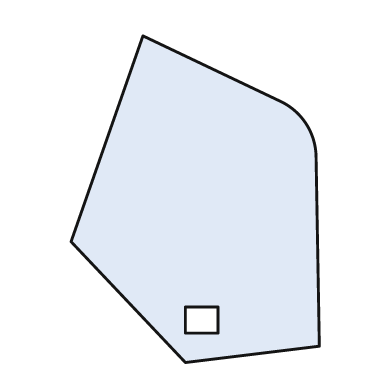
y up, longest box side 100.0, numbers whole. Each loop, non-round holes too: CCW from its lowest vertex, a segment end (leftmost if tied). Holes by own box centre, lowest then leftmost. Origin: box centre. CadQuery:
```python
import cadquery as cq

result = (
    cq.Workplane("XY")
    .moveTo(-3.0, -50.0)
    .lineTo(38.0, -45.0)
    .lineTo(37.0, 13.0)
    .threePointArc((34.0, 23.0), (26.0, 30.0))
    .lineTo(-16.0, 50.0)
    .lineTo(-38.0, -13.0)
    .close()
    .moveTo(-3.0, -41.0)
    .lineTo(7.0, -41.0)
    .lineTo(7.0, -33.0)
    .lineTo(-3.0, -33.0)
    .close()
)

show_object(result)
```